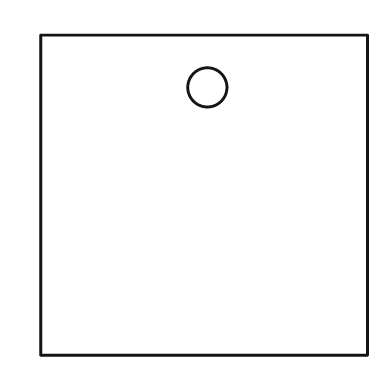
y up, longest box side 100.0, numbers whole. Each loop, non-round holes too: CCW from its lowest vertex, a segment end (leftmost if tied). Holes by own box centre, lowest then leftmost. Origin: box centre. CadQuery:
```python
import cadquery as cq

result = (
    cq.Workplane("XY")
    .moveTo(-50.0, -49.0)
    .lineTo(50.0, -49.0)
    .lineTo(50.0, 49.0)
    .lineTo(-50.0, 49.0)
    .close()
    .moveTo(1.0, 33.0)
    .circle(6.0)
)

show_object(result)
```